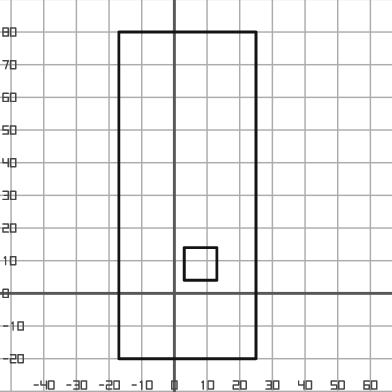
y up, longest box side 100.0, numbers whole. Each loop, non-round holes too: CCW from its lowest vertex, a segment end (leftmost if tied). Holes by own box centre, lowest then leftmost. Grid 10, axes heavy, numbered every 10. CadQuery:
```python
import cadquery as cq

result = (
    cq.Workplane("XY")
    .moveTo(-17.0, -20.0)
    .lineTo(25.0, -20.0)
    .lineTo(25.0, 80.0)
    .lineTo(-17.0, 80.0)
    .close()
    .moveTo(3.0, 4.0)
    .lineTo(13.0, 4.0)
    .lineTo(13.0, 14.0)
    .lineTo(3.0, 14.0)
    .close()
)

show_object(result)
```